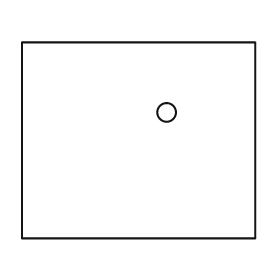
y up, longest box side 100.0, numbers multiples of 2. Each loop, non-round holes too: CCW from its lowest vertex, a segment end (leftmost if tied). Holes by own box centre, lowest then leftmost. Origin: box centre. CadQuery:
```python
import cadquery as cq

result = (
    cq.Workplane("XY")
    .moveTo(-50.0, -42.0)
    .lineTo(50.0, -42.0)
    .lineTo(50.0, 42.0)
    .lineTo(-50.0, 42.0)
    .close()
    .moveTo(12.0, 12.0)
    .circle(4.0)
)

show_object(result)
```